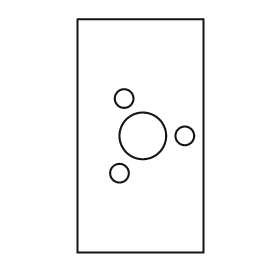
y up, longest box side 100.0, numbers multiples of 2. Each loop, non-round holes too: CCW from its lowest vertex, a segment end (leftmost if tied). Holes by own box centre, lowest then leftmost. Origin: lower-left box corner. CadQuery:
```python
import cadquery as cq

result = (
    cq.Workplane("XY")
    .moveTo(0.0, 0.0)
    .lineTo(54.0, 0.0)
    .lineTo(54.0, 100.0)
    .lineTo(0.0, 100.0)
    .close()
    .moveTo(18.0, 34.0)
    .circle(4.0)
    .moveTo(28.0, 50.0)
    .circle(10.0)
    .moveTo(46.0, 50.0)
    .circle(4.0)
    .moveTo(20.0, 66.0)
    .circle(4.0)
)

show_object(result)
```